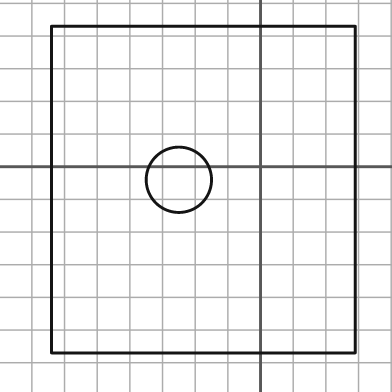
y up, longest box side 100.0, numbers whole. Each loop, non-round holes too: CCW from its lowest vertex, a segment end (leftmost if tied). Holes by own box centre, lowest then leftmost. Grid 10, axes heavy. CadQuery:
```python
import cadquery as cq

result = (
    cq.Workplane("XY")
    .moveTo(-64.0, -57.0)
    .lineTo(29.0, -57.0)
    .lineTo(29.0, 43.0)
    .lineTo(-64.0, 43.0)
    .close()
    .moveTo(-25.0, -4.0)
    .circle(10.0)
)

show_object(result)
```